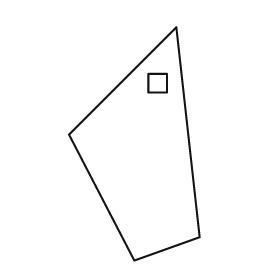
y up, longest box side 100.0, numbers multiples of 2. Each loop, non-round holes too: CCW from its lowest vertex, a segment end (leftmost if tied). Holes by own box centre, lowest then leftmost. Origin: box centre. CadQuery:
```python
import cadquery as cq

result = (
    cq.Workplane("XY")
    .moveTo(0.0, -50.0)
    .lineTo(28.0, -40.0)
    .lineTo(18.0, 50.0)
    .lineTo(-28.0, 4.0)
    .close()
    .moveTo(6.0, 22.0)
    .lineTo(14.0, 22.0)
    .lineTo(14.0, 30.0)
    .lineTo(6.0, 30.0)
    .close()
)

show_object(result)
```